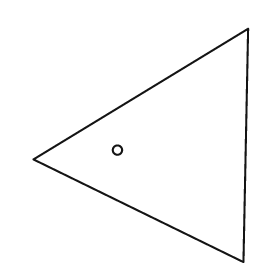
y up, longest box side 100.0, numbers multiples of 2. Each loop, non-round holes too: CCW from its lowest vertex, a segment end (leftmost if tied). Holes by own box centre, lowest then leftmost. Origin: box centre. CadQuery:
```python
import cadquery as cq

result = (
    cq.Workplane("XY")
    .moveTo(44.0, -50.0)
    .lineTo(46.0, 50.0)
    .lineTo(-46.0, -6.0)
    .close()
    .moveTo(-10.0, -2.0)
    .circle(2.0)
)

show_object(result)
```